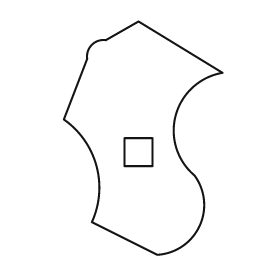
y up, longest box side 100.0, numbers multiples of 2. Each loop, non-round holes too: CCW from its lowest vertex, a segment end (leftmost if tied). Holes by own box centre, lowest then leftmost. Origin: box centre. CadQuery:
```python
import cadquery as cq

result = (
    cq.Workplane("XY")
    .moveTo(6.0, -50.0)
    .threePointArc((24.0, -38.0), (22.0, -16.0))
    .threePointArc((14.0, 10.0), (34.0, 28.0))
    .lineTo(-2.0, 50.0)
    .lineTo(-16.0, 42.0)
    .threePointArc((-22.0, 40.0), (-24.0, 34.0))
    .lineTo(-34.0, 8.0)
    .threePointArc((-20.0, -12.0), (-22.0, -36.0))
    .close()
    .moveTo(-8.0, -12.0)
    .lineTo(4.0, -12.0)
    .lineTo(4.0, 0.0)
    .lineTo(-8.0, 0.0)
    .close()
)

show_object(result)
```